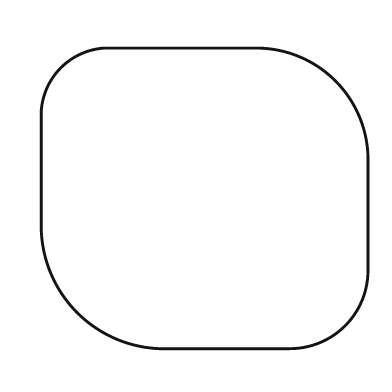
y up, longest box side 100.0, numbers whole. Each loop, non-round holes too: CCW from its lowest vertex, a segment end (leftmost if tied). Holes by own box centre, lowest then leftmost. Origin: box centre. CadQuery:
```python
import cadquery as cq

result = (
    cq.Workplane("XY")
    .moveTo(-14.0, -46.0)
    .lineTo(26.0, -46.0)
    .threePointArc((43.0, -39.0), (50.0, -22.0))
    .lineTo(50.0, 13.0)
    .threePointArc((40.0, 36.0), (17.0, 46.0))
    .lineTo(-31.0, 46.0)
    .threePointArc((-44.0, 40.0), (-50.0, 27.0))
    .lineTo(-50.0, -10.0)
    .threePointArc((-39.0, -35.0), (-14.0, -46.0))
    .close()
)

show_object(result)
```